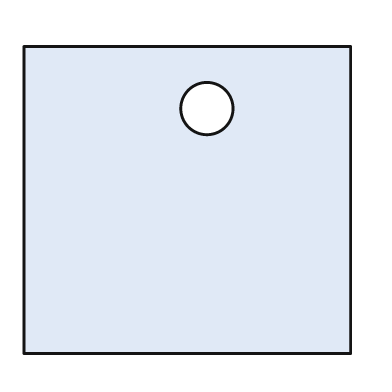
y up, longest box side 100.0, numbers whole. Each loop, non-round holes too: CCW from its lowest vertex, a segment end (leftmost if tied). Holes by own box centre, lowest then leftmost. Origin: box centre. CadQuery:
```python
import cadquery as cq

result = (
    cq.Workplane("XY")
    .moveTo(-50.0, -47.0)
    .lineTo(50.0, -47.0)
    .lineTo(50.0, 47.0)
    .lineTo(-50.0, 47.0)
    .close()
    .moveTo(6.0, 28.0)
    .circle(8.0)
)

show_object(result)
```